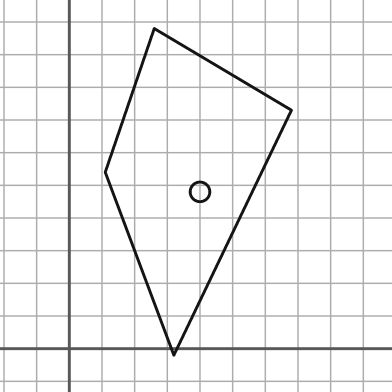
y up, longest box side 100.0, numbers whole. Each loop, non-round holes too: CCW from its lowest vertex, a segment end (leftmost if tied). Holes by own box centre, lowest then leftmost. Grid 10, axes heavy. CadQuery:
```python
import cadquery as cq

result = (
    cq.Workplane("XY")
    .moveTo(32.0, -2.0)
    .lineTo(68.0, 73.0)
    .lineTo(26.0, 98.0)
    .lineTo(11.0, 54.0)
    .close()
    .moveTo(40.0, 48.0)
    .circle(3.0)
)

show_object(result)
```